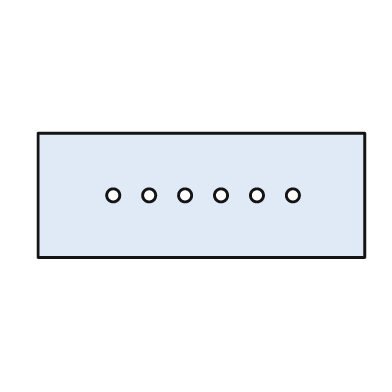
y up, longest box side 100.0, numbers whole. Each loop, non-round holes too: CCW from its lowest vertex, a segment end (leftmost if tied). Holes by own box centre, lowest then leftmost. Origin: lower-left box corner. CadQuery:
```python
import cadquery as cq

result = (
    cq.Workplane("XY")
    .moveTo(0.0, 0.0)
    .lineTo(100.0, 0.0)
    .lineTo(100.0, 38.0)
    .lineTo(0.0, 38.0)
    .close()
    .moveTo(23.0, 19.0)
    .circle(2.0)
    .moveTo(34.0, 19.0)
    .circle(2.0)
    .moveTo(45.0, 19.0)
    .circle(2.0)
    .moveTo(56.0, 19.0)
    .circle(2.0)
    .moveTo(67.0, 19.0)
    .circle(2.0)
    .moveTo(78.0, 19.0)
    .circle(2.0)
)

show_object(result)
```